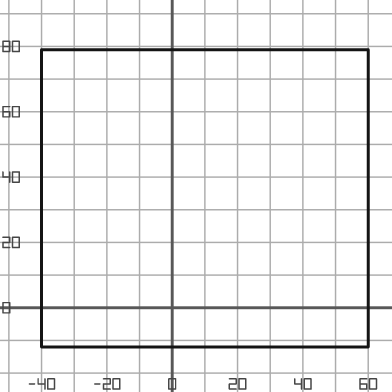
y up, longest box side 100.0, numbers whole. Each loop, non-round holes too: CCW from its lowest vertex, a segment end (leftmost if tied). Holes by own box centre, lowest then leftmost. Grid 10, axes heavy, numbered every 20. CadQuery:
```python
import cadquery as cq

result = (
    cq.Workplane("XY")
    .moveTo(-40.0, -12.0)
    .lineTo(60.0, -12.0)
    .lineTo(60.0, 79.0)
    .lineTo(-40.0, 79.0)
    .close()
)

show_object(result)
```